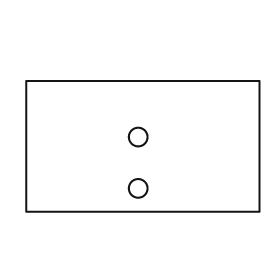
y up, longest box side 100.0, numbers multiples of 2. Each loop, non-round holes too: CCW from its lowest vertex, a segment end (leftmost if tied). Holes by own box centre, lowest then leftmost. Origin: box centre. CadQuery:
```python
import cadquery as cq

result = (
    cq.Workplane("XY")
    .moveTo(-50.0, -28.0)
    .lineTo(50.0, -28.0)
    .lineTo(50.0, 28.0)
    .lineTo(-50.0, 28.0)
    .close()
    .moveTo(-2.0, -18.0)
    .circle(4.0)
    .moveTo(-2.0, 4.0)
    .circle(4.0)
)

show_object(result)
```